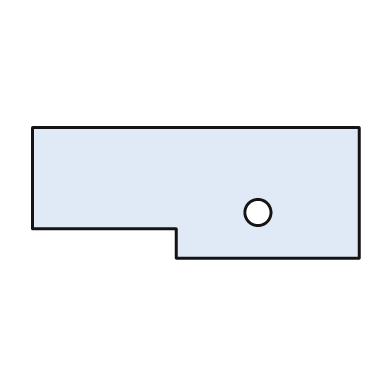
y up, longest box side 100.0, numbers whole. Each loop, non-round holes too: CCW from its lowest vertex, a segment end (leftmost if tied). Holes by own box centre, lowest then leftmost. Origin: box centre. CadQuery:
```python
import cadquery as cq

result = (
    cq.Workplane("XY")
    .moveTo(-6.0, -20.0)
    .lineTo(50.0, -20.0)
    .lineTo(50.0, 20.0)
    .lineTo(-50.0, 20.0)
    .lineTo(-50.0, -11.0)
    .lineTo(-6.0, -11.0)
    .close()
    .moveTo(19.0, -6.0)
    .circle(4.0)
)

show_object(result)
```